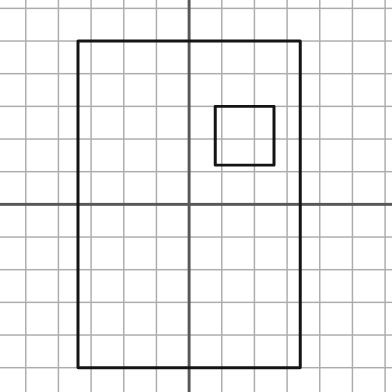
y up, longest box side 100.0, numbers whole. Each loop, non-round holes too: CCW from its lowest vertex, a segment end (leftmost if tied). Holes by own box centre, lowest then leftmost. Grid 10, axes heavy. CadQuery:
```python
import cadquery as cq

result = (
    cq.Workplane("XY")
    .moveTo(-34.0, -50.0)
    .lineTo(34.0, -50.0)
    .lineTo(34.0, 50.0)
    .lineTo(-34.0, 50.0)
    .close()
    .moveTo(8.0, 12.0)
    .lineTo(26.0, 12.0)
    .lineTo(26.0, 30.0)
    .lineTo(8.0, 30.0)
    .close()
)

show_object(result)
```